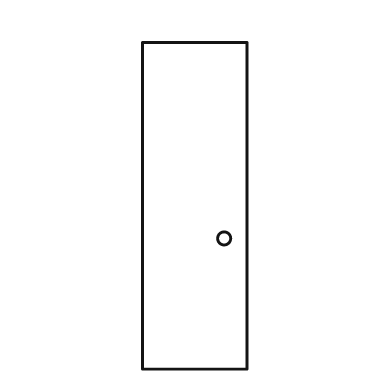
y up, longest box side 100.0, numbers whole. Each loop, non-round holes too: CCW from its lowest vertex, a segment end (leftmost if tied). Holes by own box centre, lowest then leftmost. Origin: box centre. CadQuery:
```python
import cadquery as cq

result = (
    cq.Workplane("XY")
    .moveTo(-16.0, -50.0)
    .lineTo(16.0, -50.0)
    .lineTo(16.0, 50.0)
    .lineTo(-16.0, 50.0)
    .close()
    .moveTo(9.0, -10.0)
    .circle(2.0)
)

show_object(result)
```